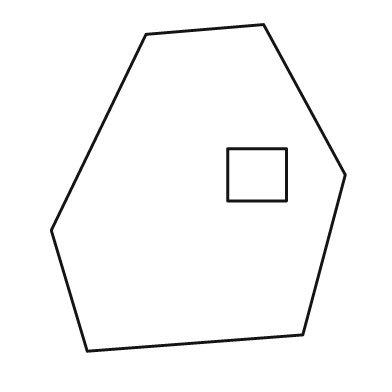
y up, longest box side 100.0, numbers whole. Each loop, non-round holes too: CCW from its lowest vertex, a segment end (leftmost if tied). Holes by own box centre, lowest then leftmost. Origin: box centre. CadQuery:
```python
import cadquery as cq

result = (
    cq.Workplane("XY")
    .moveTo(-34.0, -50.0)
    .lineTo(32.0, -45.0)
    .lineTo(45.0, 4.0)
    .lineTo(20.0, 50.0)
    .lineTo(-16.0, 47.0)
    .lineTo(-45.0, -13.0)
    .close()
    .moveTo(9.0, -4.0)
    .lineTo(27.0, -4.0)
    .lineTo(27.0, 12.0)
    .lineTo(9.0, 12.0)
    .close()
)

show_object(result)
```